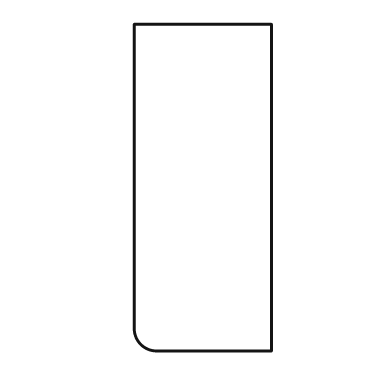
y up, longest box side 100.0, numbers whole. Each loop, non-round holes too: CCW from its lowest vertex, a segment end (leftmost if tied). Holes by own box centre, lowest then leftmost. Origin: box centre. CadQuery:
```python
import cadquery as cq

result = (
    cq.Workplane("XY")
    .moveTo(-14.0, -50.0)
    .lineTo(21.0, -50.0)
    .lineTo(21.0, 50.0)
    .lineTo(-21.0, 50.0)
    .lineTo(-21.0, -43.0)
    .threePointArc((-19.0, -48.0), (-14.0, -50.0))
    .close()
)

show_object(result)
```